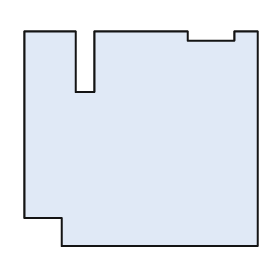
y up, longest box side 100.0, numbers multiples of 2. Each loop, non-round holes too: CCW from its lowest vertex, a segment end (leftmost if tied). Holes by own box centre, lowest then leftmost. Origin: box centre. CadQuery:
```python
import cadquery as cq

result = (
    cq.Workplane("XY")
    .moveTo(-34.0, -46.0)
    .lineTo(50.0, -46.0)
    .lineTo(50.0, 46.0)
    .lineTo(40.0, 46.0)
    .lineTo(40.0, 42.0)
    .lineTo(20.0, 42.0)
    .lineTo(20.0, 46.0)
    .lineTo(-20.0, 46.0)
    .lineTo(-20.0, 20.0)
    .lineTo(-28.0, 20.0)
    .lineTo(-28.0, 46.0)
    .lineTo(-50.0, 46.0)
    .lineTo(-50.0, -34.0)
    .lineTo(-34.0, -34.0)
    .close()
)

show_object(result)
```